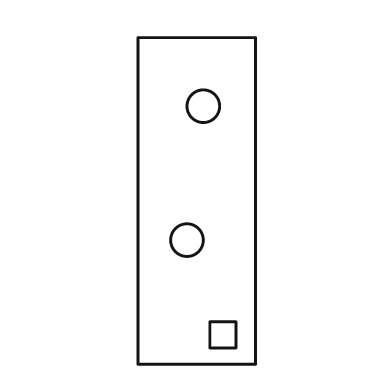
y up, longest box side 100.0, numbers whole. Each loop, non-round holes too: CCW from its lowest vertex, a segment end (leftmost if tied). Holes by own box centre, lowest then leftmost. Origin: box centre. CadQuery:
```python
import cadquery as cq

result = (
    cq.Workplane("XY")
    .moveTo(-18.0, -50.0)
    .lineTo(18.0, -50.0)
    .lineTo(18.0, 50.0)
    .lineTo(-18.0, 50.0)
    .close()
    .moveTo(4.0, -45.0)
    .lineTo(12.0, -45.0)
    .lineTo(12.0, -37.0)
    .lineTo(4.0, -37.0)
    .close()
    .moveTo(-3.0, -12.0)
    .circle(5.0)
    .moveTo(2.0, 29.0)
    .circle(5.0)
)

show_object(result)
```